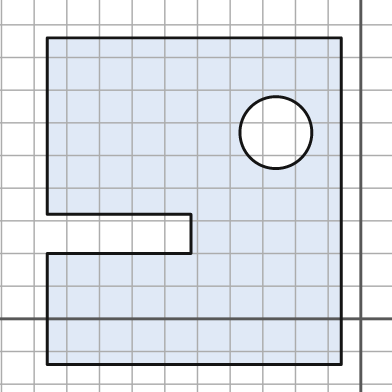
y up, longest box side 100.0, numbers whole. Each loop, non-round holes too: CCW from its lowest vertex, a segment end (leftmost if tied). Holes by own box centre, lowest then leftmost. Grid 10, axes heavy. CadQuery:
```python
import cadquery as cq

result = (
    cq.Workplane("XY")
    .moveTo(-96.0, -14.0)
    .lineTo(-6.0, -14.0)
    .lineTo(-6.0, 86.0)
    .lineTo(-96.0, 86.0)
    .lineTo(-96.0, 32.0)
    .lineTo(-52.0, 32.0)
    .lineTo(-52.0, 20.0)
    .lineTo(-96.0, 20.0)
    .close()
    .moveTo(-26.0, 57.0)
    .circle(11.0)
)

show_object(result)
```